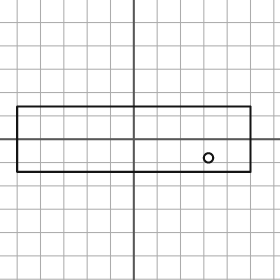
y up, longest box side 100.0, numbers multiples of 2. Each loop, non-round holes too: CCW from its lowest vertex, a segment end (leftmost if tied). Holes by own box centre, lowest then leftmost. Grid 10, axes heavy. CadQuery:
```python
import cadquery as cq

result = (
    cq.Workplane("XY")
    .moveTo(-50.0, -14.0)
    .lineTo(50.0, -14.0)
    .lineTo(50.0, 14.0)
    .lineTo(-50.0, 14.0)
    .close()
    .moveTo(32.0, -8.0)
    .circle(2.0)
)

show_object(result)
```